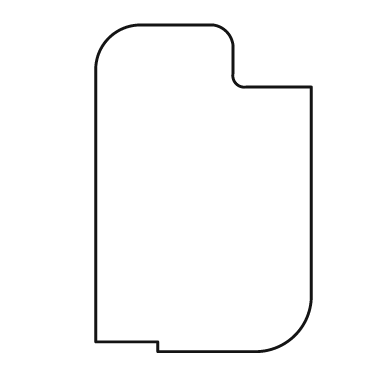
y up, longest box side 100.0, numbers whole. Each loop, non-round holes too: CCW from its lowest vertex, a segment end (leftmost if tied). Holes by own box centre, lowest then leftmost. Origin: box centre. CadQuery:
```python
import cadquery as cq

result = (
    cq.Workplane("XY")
    .moveTo(-14.0, -50.0)
    .lineTo(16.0, -50.0)
    .threePointArc((28.0, -45.0), (33.0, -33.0))
    .lineTo(33.0, 31.0)
    .lineTo(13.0, 31.0)
    .threePointArc((10.0, 32.0), (9.0, 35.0))
    .lineTo(9.0, 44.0)
    .threePointArc((7.0, 48.0), (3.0, 50.0))
    .lineTo(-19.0, 50.0)
    .threePointArc((-29.0, 46.0), (-33.0, 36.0))
    .lineTo(-33.0, -47.0)
    .lineTo(-14.0, -47.0)
    .close()
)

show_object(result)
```